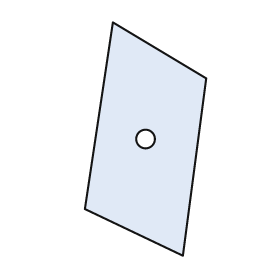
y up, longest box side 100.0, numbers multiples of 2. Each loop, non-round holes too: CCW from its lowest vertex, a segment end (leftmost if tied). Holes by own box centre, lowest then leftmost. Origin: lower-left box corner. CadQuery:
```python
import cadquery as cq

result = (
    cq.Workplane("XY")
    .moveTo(42.0, 0.0)
    .lineTo(52.0, 76.0)
    .lineTo(12.0, 100.0)
    .lineTo(0.0, 20.0)
    .close()
    .moveTo(26.0, 50.0)
    .circle(4.0)
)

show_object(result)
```